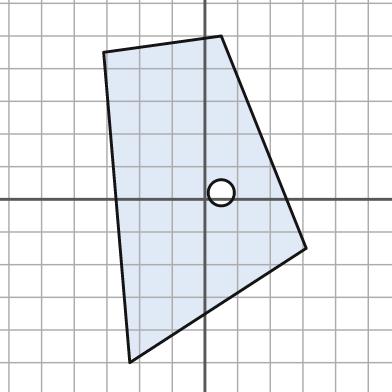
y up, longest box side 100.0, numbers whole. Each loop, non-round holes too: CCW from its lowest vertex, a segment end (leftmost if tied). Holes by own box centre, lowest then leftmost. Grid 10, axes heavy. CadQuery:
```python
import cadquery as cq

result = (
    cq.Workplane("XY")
    .moveTo(-23.0, -50.0)
    .lineTo(31.0, -15.0)
    .lineTo(5.0, 50.0)
    .lineTo(-31.0, 45.0)
    .close()
    .moveTo(5.0, 2.0)
    .circle(4.0)
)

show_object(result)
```